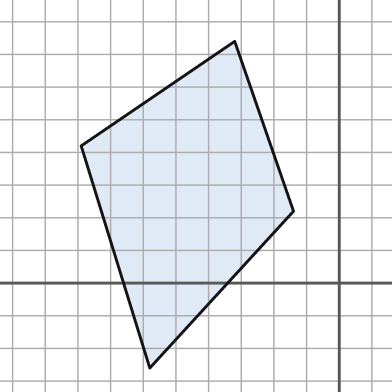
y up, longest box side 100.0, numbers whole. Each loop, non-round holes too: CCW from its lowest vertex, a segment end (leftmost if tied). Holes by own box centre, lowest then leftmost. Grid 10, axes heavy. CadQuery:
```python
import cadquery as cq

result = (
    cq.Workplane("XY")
    .moveTo(-58.0, -26.0)
    .lineTo(-14.0, 22.0)
    .lineTo(-32.0, 74.0)
    .lineTo(-79.0, 42.0)
    .close()
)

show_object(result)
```